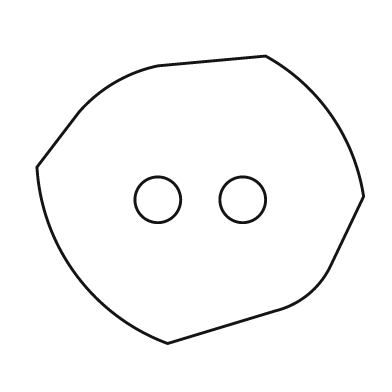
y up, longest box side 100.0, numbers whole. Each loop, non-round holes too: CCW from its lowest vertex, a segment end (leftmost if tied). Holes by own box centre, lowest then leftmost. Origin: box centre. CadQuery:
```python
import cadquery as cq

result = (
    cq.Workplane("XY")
    .moveTo(-10.0, -44.0)
    .lineTo(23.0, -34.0)
    .threePointArc((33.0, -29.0), (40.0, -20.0))
    .lineTo(50.0, 1.0)
    .threePointArc((40.0, 26.0), (20.0, 44.0))
    .lineTo(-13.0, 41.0)
    .threePointArc((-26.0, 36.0), (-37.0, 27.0))
    .lineTo(-50.0, 10.0)
    .threePointArc((-38.0, -23.0), (-10.0, -44.0))
    .close()
    .moveTo(-13.0, 0.0)
    .circle(7.0)
    .moveTo(13.0, 0.0)
    .circle(7.0)
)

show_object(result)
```